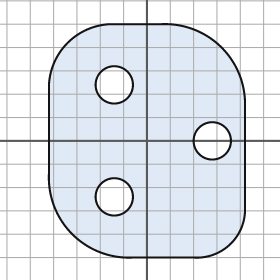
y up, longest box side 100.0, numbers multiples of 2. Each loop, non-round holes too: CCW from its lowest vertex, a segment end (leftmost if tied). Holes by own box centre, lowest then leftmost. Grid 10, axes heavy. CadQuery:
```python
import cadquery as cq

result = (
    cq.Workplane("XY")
    .moveTo(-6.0, -50.0)
    .lineTo(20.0, -50.0)
    .threePointArc((36.0, -44.0), (42.0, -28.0))
    .lineTo(42.0, 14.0)
    .threePointArc((32.0, 40.0), (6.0, 50.0))
    .lineTo(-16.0, 50.0)
    .threePointArc((-34.0, 42.0), (-42.0, 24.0))
    .lineTo(-42.0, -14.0)
    .threePointArc((-32.0, -40.0), (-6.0, -50.0))
    .close()
    .moveTo(-14.0, -24.0)
    .circle(8.0)
    .moveTo(28.0, 0.0)
    .circle(8.0)
    .moveTo(-14.0, 24.0)
    .circle(8.0)
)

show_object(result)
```